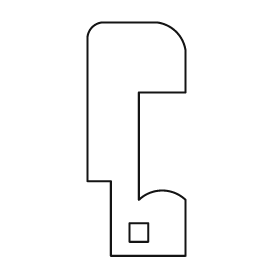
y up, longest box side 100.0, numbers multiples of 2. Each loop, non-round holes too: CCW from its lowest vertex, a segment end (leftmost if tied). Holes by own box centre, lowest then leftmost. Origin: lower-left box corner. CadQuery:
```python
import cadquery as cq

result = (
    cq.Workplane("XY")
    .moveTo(10.0, 0.0)
    .lineTo(42.0, 0.0)
    .lineTo(42.0, 24.0)
    .threePointArc((32.0, 28.0), (22.0, 24.0))
    .lineTo(22.0, 70.0)
    .lineTo(42.0, 70.0)
    .lineTo(42.0, 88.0)
    .threePointArc((38.0, 96.0), (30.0, 100.0))
    .lineTo(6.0, 100.0)
    .threePointArc((2.0, 98.0), (0.0, 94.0))
    .lineTo(0.0, 32.0)
    .lineTo(10.0, 32.0)
    .close()
    .moveTo(18.0, 6.0)
    .lineTo(26.0, 6.0)
    .lineTo(26.0, 14.0)
    .lineTo(18.0, 14.0)
    .close()
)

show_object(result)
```